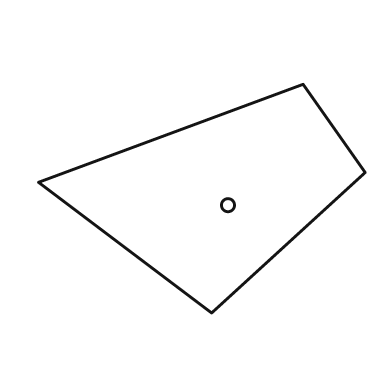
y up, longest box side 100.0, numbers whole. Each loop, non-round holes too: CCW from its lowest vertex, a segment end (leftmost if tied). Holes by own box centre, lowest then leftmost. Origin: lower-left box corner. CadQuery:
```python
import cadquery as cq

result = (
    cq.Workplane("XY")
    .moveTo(53.0, 0.0)
    .lineTo(100.0, 43.0)
    .lineTo(81.0, 70.0)
    .lineTo(0.0, 40.0)
    .close()
    .moveTo(58.0, 33.0)
    .circle(2.0)
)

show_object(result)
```